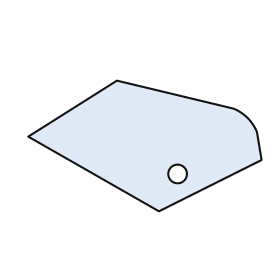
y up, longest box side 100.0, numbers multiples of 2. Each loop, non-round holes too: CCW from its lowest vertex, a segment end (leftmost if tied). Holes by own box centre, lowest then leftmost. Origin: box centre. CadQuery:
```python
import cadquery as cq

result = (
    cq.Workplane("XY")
    .moveTo(6.0, -28.0)
    .lineTo(50.0, -6.0)
    .lineTo(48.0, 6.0)
    .threePointArc((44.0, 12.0), (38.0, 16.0))
    .lineTo(-12.0, 28.0)
    .lineTo(-50.0, 4.0)
    .close()
    .moveTo(14.0, -12.0)
    .circle(4.0)
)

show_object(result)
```